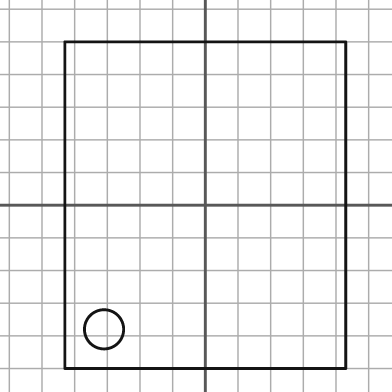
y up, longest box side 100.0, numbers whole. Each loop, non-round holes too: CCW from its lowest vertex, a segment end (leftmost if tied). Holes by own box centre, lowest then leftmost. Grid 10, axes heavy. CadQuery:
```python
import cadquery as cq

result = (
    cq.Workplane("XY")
    .moveTo(-43.0, -50.0)
    .lineTo(43.0, -50.0)
    .lineTo(43.0, 50.0)
    .lineTo(-43.0, 50.0)
    .close()
    .moveTo(-31.0, -38.0)
    .circle(6.0)
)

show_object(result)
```